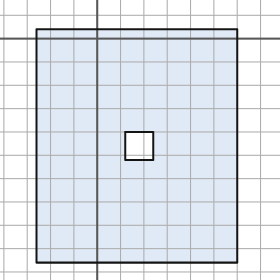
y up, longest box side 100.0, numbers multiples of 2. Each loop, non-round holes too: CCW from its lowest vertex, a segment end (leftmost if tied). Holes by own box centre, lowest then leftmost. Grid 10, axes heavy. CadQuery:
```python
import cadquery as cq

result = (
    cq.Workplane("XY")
    .moveTo(-26.0, -96.0)
    .lineTo(60.0, -96.0)
    .lineTo(60.0, 4.0)
    .lineTo(-26.0, 4.0)
    .close()
    .moveTo(12.0, -52.0)
    .lineTo(24.0, -52.0)
    .lineTo(24.0, -40.0)
    .lineTo(12.0, -40.0)
    .close()
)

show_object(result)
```